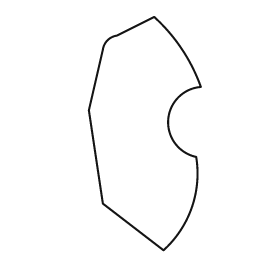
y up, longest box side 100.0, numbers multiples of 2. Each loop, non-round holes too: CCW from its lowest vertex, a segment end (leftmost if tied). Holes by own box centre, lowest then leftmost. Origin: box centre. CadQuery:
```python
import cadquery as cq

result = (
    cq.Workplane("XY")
    .moveTo(8.0, -50.0)
    .threePointArc((20.0, -32.0), (22.0, -10.0))
    .threePointArc((10.0, 6.0), (24.0, 20.0))
    .threePointArc((16.0, 36.0), (4.0, 50.0))
    .lineTo(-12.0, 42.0)
    .threePointArc((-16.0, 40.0), (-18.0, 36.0))
    .lineTo(-24.0, 10.0)
    .lineTo(-18.0, -30.0)
    .close()
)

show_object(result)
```